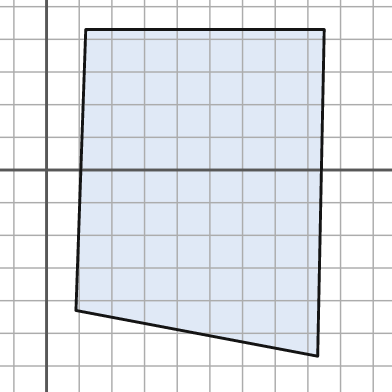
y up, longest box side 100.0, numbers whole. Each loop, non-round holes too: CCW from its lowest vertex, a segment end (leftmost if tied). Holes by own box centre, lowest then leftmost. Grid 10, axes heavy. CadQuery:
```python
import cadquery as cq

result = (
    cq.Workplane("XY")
    .moveTo(83.0, -57.0)
    .lineTo(85.0, 43.0)
    .lineTo(12.0, 43.0)
    .lineTo(9.0, -43.0)
    .close()
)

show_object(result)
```